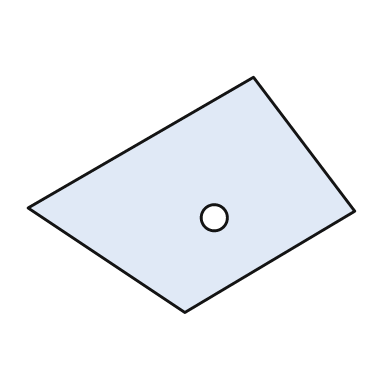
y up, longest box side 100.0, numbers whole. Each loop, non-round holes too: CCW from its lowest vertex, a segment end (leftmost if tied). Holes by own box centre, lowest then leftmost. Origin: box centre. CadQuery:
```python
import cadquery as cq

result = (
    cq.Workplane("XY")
    .moveTo(-2.0, -36.0)
    .lineTo(50.0, -5.0)
    .lineTo(19.0, 36.0)
    .lineTo(-50.0, -4.0)
    .close()
    .moveTo(7.0, -7.0)
    .circle(4.0)
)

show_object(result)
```